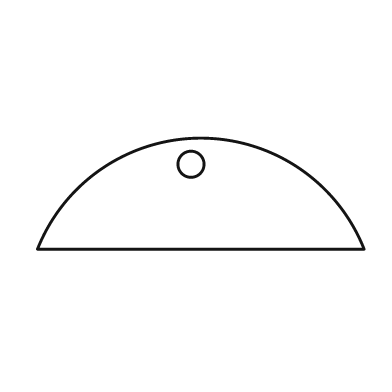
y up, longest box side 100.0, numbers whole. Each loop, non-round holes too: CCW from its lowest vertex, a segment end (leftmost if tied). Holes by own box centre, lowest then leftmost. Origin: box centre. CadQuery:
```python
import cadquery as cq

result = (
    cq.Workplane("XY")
    .moveTo(-50.0, -17.0)
    .lineTo(50.0, -17.0)
    .threePointArc((0.0, 17.0), (-50.0, -17.0))
    .close()
    .moveTo(-3.0, 9.0)
    .circle(4.0)
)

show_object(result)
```